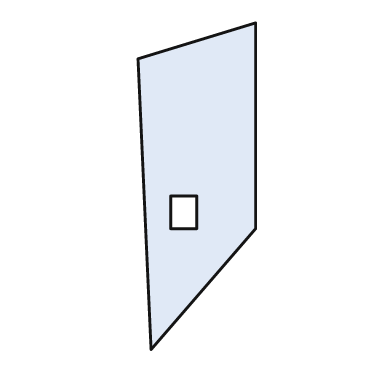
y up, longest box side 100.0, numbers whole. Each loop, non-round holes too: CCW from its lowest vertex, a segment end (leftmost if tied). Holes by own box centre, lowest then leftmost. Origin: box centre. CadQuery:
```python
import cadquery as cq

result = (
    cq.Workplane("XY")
    .moveTo(-14.0, -50.0)
    .lineTo(18.0, -13.0)
    .lineTo(18.0, 50.0)
    .lineTo(-18.0, 39.0)
    .close()
    .moveTo(-8.0, -13.0)
    .lineTo(0.0, -13.0)
    .lineTo(0.0, -3.0)
    .lineTo(-8.0, -3.0)
    .close()
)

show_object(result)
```